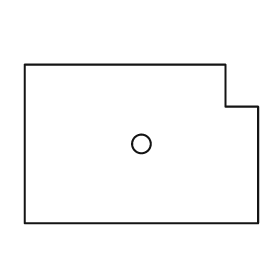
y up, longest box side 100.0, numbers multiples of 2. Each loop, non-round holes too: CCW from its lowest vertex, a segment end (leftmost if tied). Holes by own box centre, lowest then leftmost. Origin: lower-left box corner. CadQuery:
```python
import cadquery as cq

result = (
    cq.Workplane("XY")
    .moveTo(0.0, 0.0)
    .lineTo(100.0, 0.0)
    .lineTo(100.0, 50.0)
    .lineTo(86.0, 50.0)
    .lineTo(86.0, 68.0)
    .lineTo(0.0, 68.0)
    .close()
    .moveTo(50.0, 34.0)
    .circle(4.0)
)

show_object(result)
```